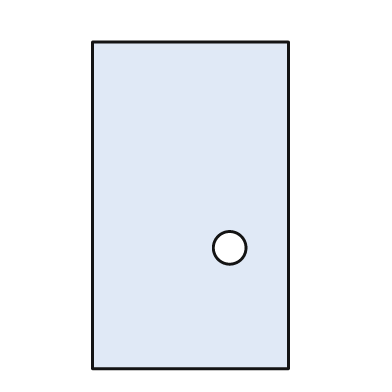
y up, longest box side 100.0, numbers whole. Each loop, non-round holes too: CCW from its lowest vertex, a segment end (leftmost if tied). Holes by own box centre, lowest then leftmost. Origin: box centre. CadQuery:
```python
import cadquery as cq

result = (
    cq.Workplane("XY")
    .moveTo(-30.0, -50.0)
    .lineTo(30.0, -50.0)
    .lineTo(30.0, 50.0)
    .lineTo(-30.0, 50.0)
    .close()
    .moveTo(12.0, -13.0)
    .circle(5.0)
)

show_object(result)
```